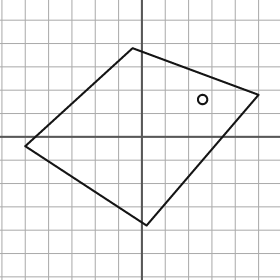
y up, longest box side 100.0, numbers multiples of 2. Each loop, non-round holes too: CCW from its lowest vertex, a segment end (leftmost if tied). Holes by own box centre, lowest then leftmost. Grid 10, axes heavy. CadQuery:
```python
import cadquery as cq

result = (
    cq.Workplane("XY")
    .moveTo(2.0, -38.0)
    .lineTo(50.0, 18.0)
    .lineTo(-4.0, 38.0)
    .lineTo(-50.0, -4.0)
    .close()
    .moveTo(26.0, 16.0)
    .circle(2.0)
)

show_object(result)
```